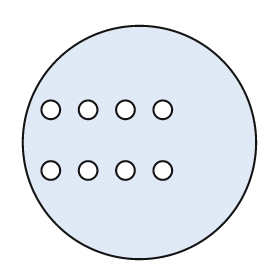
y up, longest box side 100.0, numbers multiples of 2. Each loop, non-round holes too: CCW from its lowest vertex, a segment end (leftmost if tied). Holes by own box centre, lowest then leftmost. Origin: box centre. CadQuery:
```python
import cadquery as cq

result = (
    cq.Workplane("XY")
    .moveTo(0.0, 0.0)
    .circle(50.0)
    .moveTo(-38.0, -12.0)
    .circle(4.0)
    .moveTo(-22.0, -12.0)
    .circle(4.0)
    .moveTo(-6.0, -12.0)
    .circle(4.0)
    .moveTo(10.0, -12.0)
    .circle(4.0)
    .moveTo(-38.0, 14.0)
    .circle(4.0)
    .moveTo(-22.0, 14.0)
    .circle(4.0)
    .moveTo(-6.0, 14.0)
    .circle(4.0)
    .moveTo(10.0, 14.0)
    .circle(4.0)
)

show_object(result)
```